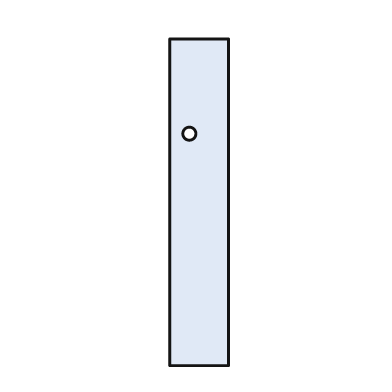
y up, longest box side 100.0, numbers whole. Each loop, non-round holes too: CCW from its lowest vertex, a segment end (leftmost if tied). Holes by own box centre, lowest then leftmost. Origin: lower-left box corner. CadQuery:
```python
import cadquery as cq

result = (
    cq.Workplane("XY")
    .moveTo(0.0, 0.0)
    .lineTo(18.0, 0.0)
    .lineTo(18.0, 100.0)
    .lineTo(0.0, 100.0)
    .close()
    .moveTo(6.0, 71.0)
    .circle(2.0)
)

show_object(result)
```